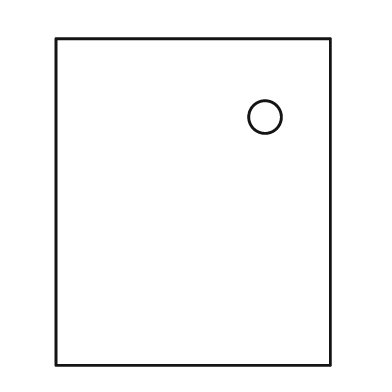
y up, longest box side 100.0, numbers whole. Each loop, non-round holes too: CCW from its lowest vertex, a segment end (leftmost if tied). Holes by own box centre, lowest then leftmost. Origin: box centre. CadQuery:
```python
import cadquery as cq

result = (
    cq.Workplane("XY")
    .moveTo(-42.0, -50.0)
    .lineTo(42.0, -50.0)
    .lineTo(42.0, 50.0)
    .lineTo(-42.0, 50.0)
    .close()
    .moveTo(22.0, 26.0)
    .circle(5.0)
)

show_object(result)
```